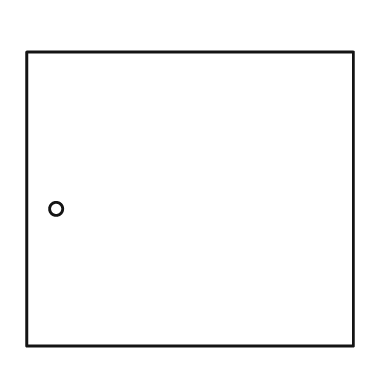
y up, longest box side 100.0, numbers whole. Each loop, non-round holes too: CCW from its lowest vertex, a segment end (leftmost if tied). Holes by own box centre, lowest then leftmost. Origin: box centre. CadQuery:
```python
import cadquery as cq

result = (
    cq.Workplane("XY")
    .moveTo(-50.0, -45.0)
    .lineTo(50.0, -45.0)
    .lineTo(50.0, 45.0)
    .lineTo(-50.0, 45.0)
    .close()
    .moveTo(-41.0, -3.0)
    .circle(2.0)
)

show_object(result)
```